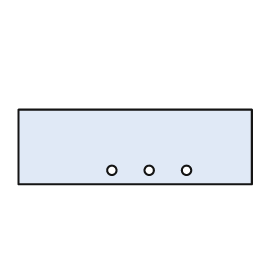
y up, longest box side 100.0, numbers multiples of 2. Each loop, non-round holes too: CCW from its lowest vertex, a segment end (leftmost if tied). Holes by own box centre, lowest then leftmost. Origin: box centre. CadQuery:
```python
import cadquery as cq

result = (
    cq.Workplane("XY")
    .moveTo(-50.0, -16.0)
    .lineTo(50.0, -16.0)
    .lineTo(50.0, 16.0)
    .lineTo(-50.0, 16.0)
    .close()
    .moveTo(-10.0, -10.0)
    .circle(2.0)
    .moveTo(6.0, -10.0)
    .circle(2.0)
    .moveTo(22.0, -10.0)
    .circle(2.0)
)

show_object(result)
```